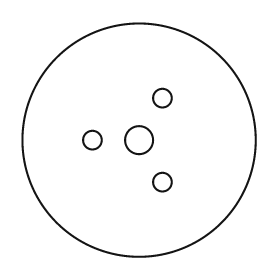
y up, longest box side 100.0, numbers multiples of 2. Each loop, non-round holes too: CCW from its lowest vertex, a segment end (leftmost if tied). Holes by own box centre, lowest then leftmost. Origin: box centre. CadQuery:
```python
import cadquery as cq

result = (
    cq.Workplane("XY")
    .moveTo(0.0, 0.0)
    .circle(50.0)
    .moveTo(10.0, -18.0)
    .circle(4.0)
    .moveTo(-20.0, 0.0)
    .circle(4.0)
    .moveTo(0.0, 0.0)
    .circle(6.0)
    .moveTo(10.0, 18.0)
    .circle(4.0)
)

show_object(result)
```